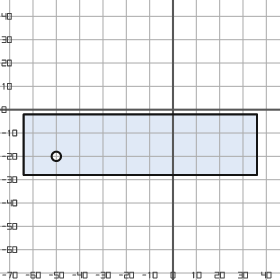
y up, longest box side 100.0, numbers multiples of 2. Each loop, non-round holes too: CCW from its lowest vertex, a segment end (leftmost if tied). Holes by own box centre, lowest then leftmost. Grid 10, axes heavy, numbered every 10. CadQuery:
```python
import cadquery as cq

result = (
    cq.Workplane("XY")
    .moveTo(-64.0, -28.0)
    .lineTo(36.0, -28.0)
    .lineTo(36.0, -2.0)
    .lineTo(-64.0, -2.0)
    .close()
    .moveTo(-50.0, -20.0)
    .circle(2.0)
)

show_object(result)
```